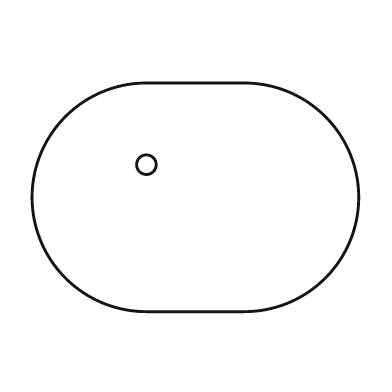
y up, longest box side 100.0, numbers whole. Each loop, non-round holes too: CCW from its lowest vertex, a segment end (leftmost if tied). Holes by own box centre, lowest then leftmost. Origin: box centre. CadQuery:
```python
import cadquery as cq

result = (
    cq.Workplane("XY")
    .moveTo(-15.0, -35.0)
    .lineTo(15.0, -35.0)
    .threePointArc((50.0, 0.0), (15.0, 35.0))
    .lineTo(-15.0, 35.0)
    .threePointArc((-50.0, 0.0), (-15.0, -35.0))
    .close()
    .moveTo(-15.0, 10.0)
    .circle(3.0)
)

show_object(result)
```